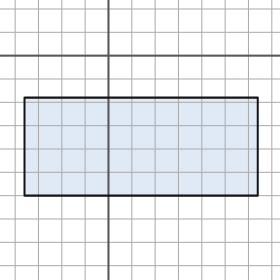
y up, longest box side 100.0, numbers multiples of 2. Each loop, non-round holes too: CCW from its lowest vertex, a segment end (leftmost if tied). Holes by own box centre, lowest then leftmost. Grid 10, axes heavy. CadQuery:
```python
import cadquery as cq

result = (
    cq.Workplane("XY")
    .moveTo(-36.0, -60.0)
    .lineTo(64.0, -60.0)
    .lineTo(64.0, -18.0)
    .lineTo(-36.0, -18.0)
    .close()
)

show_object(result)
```